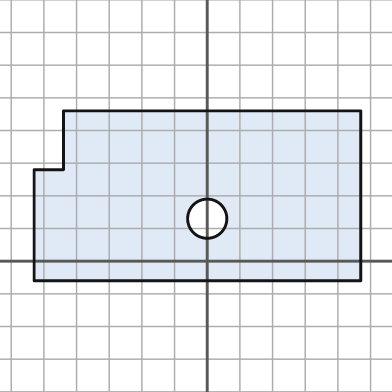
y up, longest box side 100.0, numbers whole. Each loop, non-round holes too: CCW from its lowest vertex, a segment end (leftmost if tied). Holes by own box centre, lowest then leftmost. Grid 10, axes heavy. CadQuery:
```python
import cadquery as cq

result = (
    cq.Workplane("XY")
    .moveTo(-53.0, -6.0)
    .lineTo(47.0, -6.0)
    .lineTo(47.0, 46.0)
    .lineTo(-44.0, 46.0)
    .lineTo(-44.0, 28.0)
    .lineTo(-53.0, 28.0)
    .close()
    .moveTo(0.0, 13.0)
    .circle(6.0)
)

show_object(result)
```